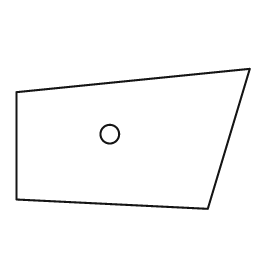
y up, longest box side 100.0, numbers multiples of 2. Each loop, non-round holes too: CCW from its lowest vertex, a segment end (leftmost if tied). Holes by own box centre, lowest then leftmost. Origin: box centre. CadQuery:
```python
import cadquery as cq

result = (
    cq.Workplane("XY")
    .moveTo(32.0, -30.0)
    .lineTo(50.0, 30.0)
    .lineTo(-50.0, 20.0)
    .lineTo(-50.0, -26.0)
    .close()
    .moveTo(-10.0, 2.0)
    .circle(4.0)
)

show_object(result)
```